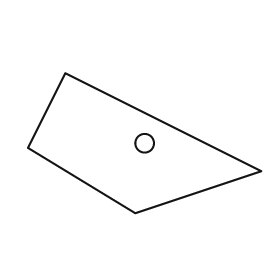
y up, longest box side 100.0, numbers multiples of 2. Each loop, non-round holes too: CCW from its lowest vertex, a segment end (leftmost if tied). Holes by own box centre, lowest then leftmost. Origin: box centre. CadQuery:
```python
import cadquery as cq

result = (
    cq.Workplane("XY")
    .moveTo(-4.0, -30.0)
    .lineTo(50.0, -12.0)
    .lineTo(-34.0, 30.0)
    .lineTo(-50.0, -2.0)
    .close()
    .moveTo(0.0, 0.0)
    .circle(4.0)
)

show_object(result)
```